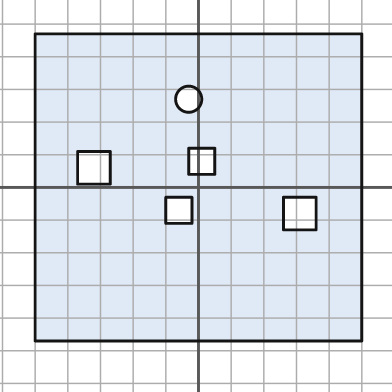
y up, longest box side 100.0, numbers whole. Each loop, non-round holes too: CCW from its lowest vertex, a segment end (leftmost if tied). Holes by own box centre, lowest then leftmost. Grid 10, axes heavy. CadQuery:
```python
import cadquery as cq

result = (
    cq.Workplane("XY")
    .moveTo(-50.0, -47.0)
    .lineTo(50.0, -47.0)
    .lineTo(50.0, 47.0)
    .lineTo(-50.0, 47.0)
    .close()
    .moveTo(26.0, -13.0)
    .lineTo(36.0, -13.0)
    .lineTo(36.0, -3.0)
    .lineTo(26.0, -3.0)
    .close()
    .moveTo(-10.0, -11.0)
    .lineTo(-2.0, -11.0)
    .lineTo(-2.0, -3.0)
    .lineTo(-10.0, -3.0)
    .close()
    .moveTo(-37.0, 1.0)
    .lineTo(-27.0, 1.0)
    .lineTo(-27.0, 11.0)
    .lineTo(-37.0, 11.0)
    .close()
    .moveTo(-3.0, 4.0)
    .lineTo(5.0, 4.0)
    .lineTo(5.0, 12.0)
    .lineTo(-3.0, 12.0)
    .close()
    .moveTo(-3.0, 27.0)
    .circle(4.0)
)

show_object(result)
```